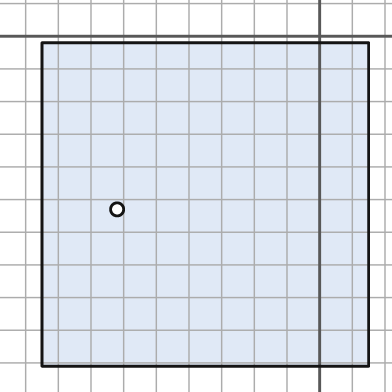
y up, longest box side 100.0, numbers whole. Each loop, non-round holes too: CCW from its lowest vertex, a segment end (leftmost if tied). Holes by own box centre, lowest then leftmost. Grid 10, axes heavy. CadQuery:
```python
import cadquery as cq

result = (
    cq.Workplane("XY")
    .moveTo(-85.0, -101.0)
    .lineTo(15.0, -101.0)
    .lineTo(15.0, -2.0)
    .lineTo(-85.0, -2.0)
    .close()
    .moveTo(-62.0, -53.0)
    .circle(2.0)
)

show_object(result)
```